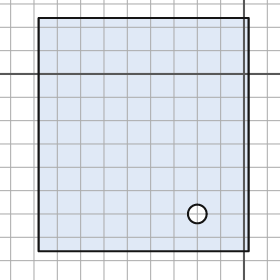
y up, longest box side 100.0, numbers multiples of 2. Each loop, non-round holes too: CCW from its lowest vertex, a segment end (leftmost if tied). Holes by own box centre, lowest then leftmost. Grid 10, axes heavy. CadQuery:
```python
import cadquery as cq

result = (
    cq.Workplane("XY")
    .moveTo(-88.0, -76.0)
    .lineTo(2.0, -76.0)
    .lineTo(2.0, 24.0)
    .lineTo(-88.0, 24.0)
    .close()
    .moveTo(-20.0, -60.0)
    .circle(4.0)
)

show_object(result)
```